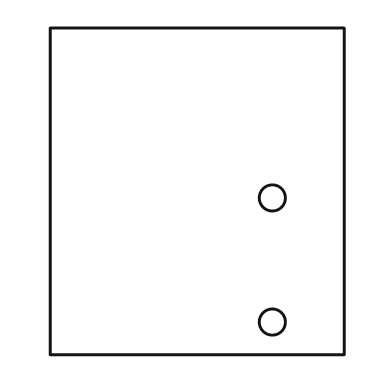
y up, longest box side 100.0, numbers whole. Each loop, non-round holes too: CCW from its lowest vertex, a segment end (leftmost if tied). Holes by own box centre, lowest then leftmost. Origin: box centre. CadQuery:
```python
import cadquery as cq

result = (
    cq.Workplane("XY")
    .moveTo(-45.0, -50.0)
    .lineTo(45.0, -50.0)
    .lineTo(45.0, 50.0)
    .lineTo(-45.0, 50.0)
    .close()
    .moveTo(23.0, -40.0)
    .circle(4.0)
    .moveTo(23.0, -2.0)
    .circle(4.0)
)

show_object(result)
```